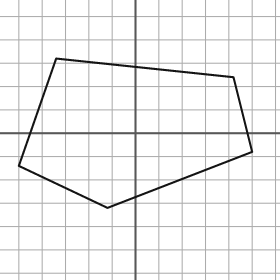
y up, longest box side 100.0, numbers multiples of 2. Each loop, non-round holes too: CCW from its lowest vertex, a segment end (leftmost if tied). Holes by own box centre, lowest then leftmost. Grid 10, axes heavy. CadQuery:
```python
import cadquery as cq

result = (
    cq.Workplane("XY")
    .moveTo(-12.0, -32.0)
    .lineTo(50.0, -8.0)
    .lineTo(42.0, 24.0)
    .lineTo(-34.0, 32.0)
    .lineTo(-50.0, -14.0)
    .close()
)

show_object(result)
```